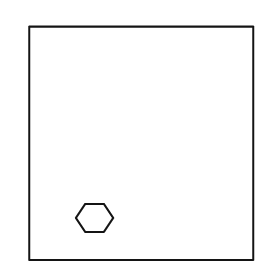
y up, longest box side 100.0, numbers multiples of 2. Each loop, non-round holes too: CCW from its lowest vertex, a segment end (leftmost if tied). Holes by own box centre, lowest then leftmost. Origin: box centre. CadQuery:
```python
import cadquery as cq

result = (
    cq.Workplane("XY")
    .moveTo(-48.0, -50.0)
    .lineTo(48.0, -50.0)
    .lineTo(48.0, 50.0)
    .lineTo(-48.0, 50.0)
    .close()
    .moveTo(-24.0, -38.0)
    .lineTo(-16.0, -38.0)
    .lineTo(-12.0, -32.0)
    .lineTo(-16.0, -26.0)
    .lineTo(-24.0, -26.0)
    .lineTo(-28.0, -32.0)
    .close()
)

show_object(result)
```